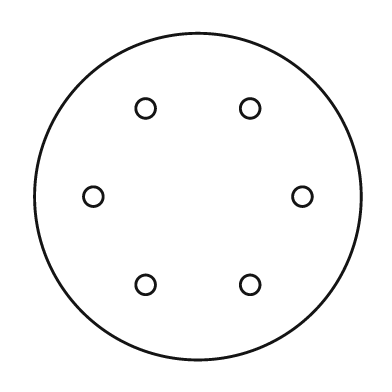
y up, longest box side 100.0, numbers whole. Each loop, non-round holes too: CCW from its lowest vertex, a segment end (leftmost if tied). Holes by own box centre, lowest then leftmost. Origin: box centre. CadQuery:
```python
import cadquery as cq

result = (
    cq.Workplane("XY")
    .moveTo(0.0, 0.0)
    .circle(50.0)
    .moveTo(-16.0, -27.0)
    .circle(3.0)
    .moveTo(16.0, -27.0)
    .circle(3.0)
    .moveTo(-32.0, 0.0)
    .circle(3.0)
    .moveTo(32.0, 0.0)
    .circle(3.0)
    .moveTo(-16.0, 27.0)
    .circle(3.0)
    .moveTo(16.0, 27.0)
    .circle(3.0)
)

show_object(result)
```